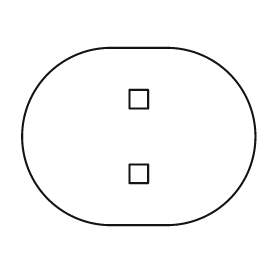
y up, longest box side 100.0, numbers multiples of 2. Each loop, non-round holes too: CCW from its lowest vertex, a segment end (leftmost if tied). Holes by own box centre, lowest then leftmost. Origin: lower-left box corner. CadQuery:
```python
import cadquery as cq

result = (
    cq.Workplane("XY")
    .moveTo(38.0, 0.0)
    .lineTo(62.0, 0.0)
    .threePointArc((100.0, 38.0), (62.0, 76.0))
    .lineTo(38.0, 76.0)
    .threePointArc((0.0, 38.0), (38.0, 0.0))
    .close()
    .moveTo(46.0, 18.0)
    .lineTo(54.0, 18.0)
    .lineTo(54.0, 26.0)
    .lineTo(46.0, 26.0)
    .close()
    .moveTo(46.0, 50.0)
    .lineTo(54.0, 50.0)
    .lineTo(54.0, 58.0)
    .lineTo(46.0, 58.0)
    .close()
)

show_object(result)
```